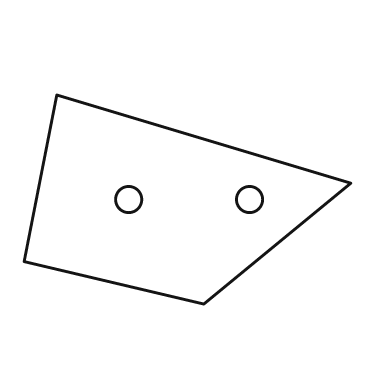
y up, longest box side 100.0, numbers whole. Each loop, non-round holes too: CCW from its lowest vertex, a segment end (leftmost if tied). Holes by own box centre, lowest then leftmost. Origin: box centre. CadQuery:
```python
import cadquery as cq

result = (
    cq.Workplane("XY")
    .moveTo(5.0, -32.0)
    .lineTo(50.0, 5.0)
    .lineTo(-40.0, 32.0)
    .lineTo(-50.0, -19.0)
    .close()
    .moveTo(-18.0, 0.0)
    .circle(4.0)
    .moveTo(19.0, 0.0)
    .circle(4.0)
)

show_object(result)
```